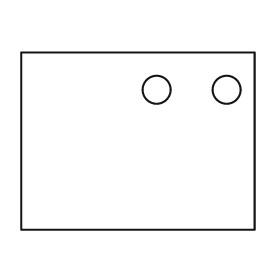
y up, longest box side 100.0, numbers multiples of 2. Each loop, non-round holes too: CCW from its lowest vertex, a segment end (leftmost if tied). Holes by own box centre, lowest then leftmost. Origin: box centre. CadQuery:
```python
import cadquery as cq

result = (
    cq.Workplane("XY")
    .moveTo(-50.0, -38.0)
    .lineTo(50.0, -38.0)
    .lineTo(50.0, 38.0)
    .lineTo(-50.0, 38.0)
    .close()
    .moveTo(8.0, 22.0)
    .circle(6.0)
    .moveTo(38.0, 22.0)
    .circle(6.0)
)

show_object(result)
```